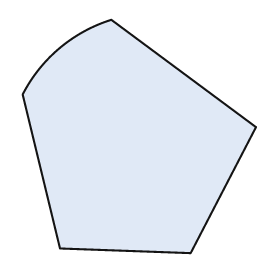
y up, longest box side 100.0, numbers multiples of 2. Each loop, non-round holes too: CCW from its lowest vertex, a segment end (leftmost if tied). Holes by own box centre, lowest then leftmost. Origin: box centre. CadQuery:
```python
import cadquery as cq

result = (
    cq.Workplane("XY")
    .moveTo(22.0, -50.0)
    .lineTo(50.0, 4.0)
    .lineTo(-12.0, 50.0)
    .threePointArc((-34.0, 38.0), (-50.0, 18.0))
    .lineTo(-34.0, -48.0)
    .close()
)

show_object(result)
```